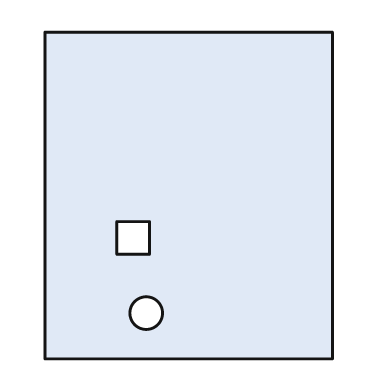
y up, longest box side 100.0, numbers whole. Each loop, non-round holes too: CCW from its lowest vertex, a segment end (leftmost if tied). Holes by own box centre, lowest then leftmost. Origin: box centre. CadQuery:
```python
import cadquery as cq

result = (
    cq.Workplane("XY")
    .moveTo(-44.0, -50.0)
    .lineTo(44.0, -50.0)
    .lineTo(44.0, 50.0)
    .lineTo(-44.0, 50.0)
    .close()
    .moveTo(-13.0, -36.0)
    .circle(5.0)
    .moveTo(-22.0, -18.0)
    .lineTo(-12.0, -18.0)
    .lineTo(-12.0, -8.0)
    .lineTo(-22.0, -8.0)
    .close()
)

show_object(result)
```